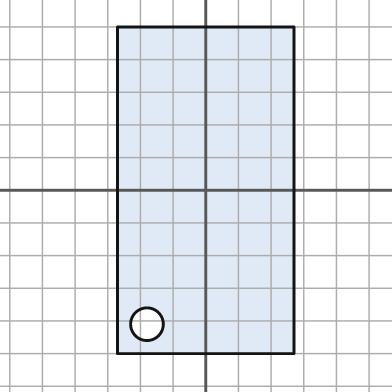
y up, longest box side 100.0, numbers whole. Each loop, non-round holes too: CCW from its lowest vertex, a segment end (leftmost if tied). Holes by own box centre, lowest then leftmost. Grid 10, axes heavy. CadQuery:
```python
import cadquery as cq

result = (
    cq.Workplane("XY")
    .moveTo(-27.0, -50.0)
    .lineTo(27.0, -50.0)
    .lineTo(27.0, 50.0)
    .lineTo(-27.0, 50.0)
    .close()
    .moveTo(-18.0, -41.0)
    .circle(5.0)
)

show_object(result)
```